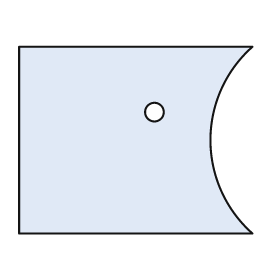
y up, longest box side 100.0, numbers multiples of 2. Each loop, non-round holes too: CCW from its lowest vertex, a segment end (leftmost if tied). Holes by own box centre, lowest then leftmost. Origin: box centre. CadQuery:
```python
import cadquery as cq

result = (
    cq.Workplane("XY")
    .moveTo(-50.0, -40.0)
    .lineTo(50.0, -40.0)
    .threePointArc((32.0, 0.0), (50.0, 40.0))
    .lineTo(-50.0, 40.0)
    .close()
    .moveTo(8.0, 12.0)
    .circle(4.0)
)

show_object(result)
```